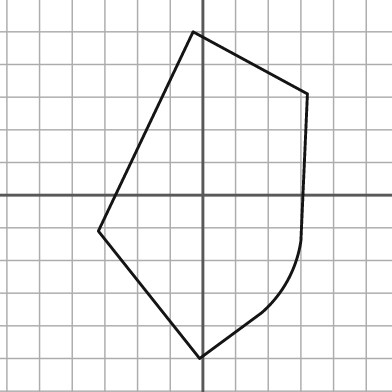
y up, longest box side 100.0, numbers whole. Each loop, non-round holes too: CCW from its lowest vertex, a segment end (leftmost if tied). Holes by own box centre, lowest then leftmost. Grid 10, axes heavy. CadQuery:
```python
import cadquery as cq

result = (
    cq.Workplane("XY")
    .moveTo(-1.0, -50.0)
    .lineTo(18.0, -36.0)
    .threePointArc((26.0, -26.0), (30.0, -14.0))
    .lineTo(32.0, 31.0)
    .lineTo(-3.0, 50.0)
    .lineTo(-32.0, -11.0)
    .close()
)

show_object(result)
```